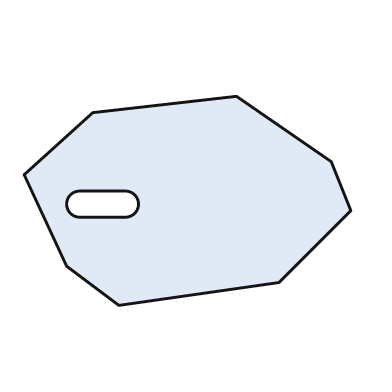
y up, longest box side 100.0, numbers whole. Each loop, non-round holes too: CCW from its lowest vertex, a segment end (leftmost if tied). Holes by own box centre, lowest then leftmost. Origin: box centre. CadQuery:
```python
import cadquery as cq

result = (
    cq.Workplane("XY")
    .moveTo(-21.0, -32.0)
    .lineTo(28.0, -25.0)
    .lineTo(50.0, -3.0)
    .lineTo(44.0, 12.0)
    .lineTo(15.0, 32.0)
    .lineTo(-29.0, 27.0)
    .lineTo(-50.0, 8.0)
    .lineTo(-37.0, -20.0)
    .close()
    .moveTo(-33.0, -5.0)
    .lineTo(-19.0, -5.0)
    .threePointArc((-15.0, -1.0), (-19.0, 3.0))
    .lineTo(-33.0, 3.0)
    .threePointArc((-37.0, -1.0), (-33.0, -5.0))
    .close()
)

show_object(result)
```